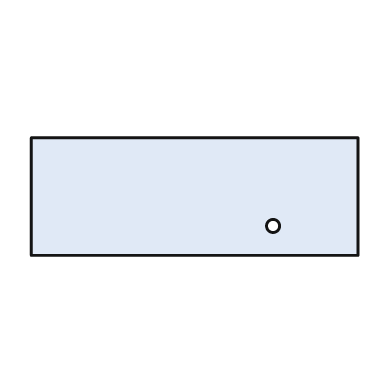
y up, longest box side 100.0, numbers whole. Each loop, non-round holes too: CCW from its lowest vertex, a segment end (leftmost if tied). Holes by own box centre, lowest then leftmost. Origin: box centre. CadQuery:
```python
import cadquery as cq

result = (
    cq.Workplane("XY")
    .moveTo(-50.0, -18.0)
    .lineTo(50.0, -18.0)
    .lineTo(50.0, 18.0)
    .lineTo(-50.0, 18.0)
    .close()
    .moveTo(24.0, -9.0)
    .circle(2.0)
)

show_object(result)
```